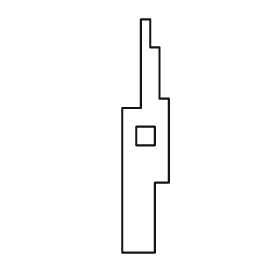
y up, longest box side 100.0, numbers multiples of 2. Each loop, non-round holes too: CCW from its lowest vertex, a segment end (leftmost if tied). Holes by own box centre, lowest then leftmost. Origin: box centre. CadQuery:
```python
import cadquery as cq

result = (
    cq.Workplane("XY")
    .moveTo(-10.0, -50.0)
    .lineTo(4.0, -50.0)
    .lineTo(4.0, -20.0)
    .lineTo(10.0, -20.0)
    .lineTo(10.0, 16.0)
    .lineTo(6.0, 16.0)
    .lineTo(6.0, 38.0)
    .lineTo(2.0, 38.0)
    .lineTo(2.0, 50.0)
    .lineTo(-2.0, 50.0)
    .lineTo(-2.0, 12.0)
    .lineTo(-10.0, 12.0)
    .close()
    .moveTo(-4.0, -4.0)
    .lineTo(4.0, -4.0)
    .lineTo(4.0, 4.0)
    .lineTo(-4.0, 4.0)
    .close()
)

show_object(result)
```